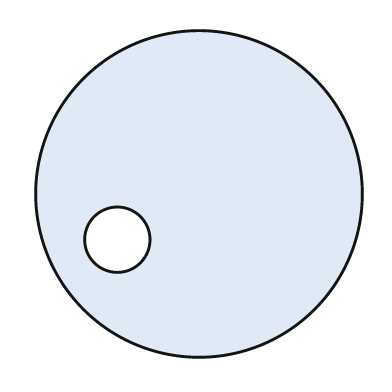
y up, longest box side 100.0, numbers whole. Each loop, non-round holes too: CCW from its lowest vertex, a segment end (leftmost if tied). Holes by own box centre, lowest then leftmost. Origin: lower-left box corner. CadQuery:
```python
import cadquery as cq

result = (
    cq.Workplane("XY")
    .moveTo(50.0, 50.0)
    .circle(50.0)
    .moveTo(25.0, 36.0)
    .circle(10.0)
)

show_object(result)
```